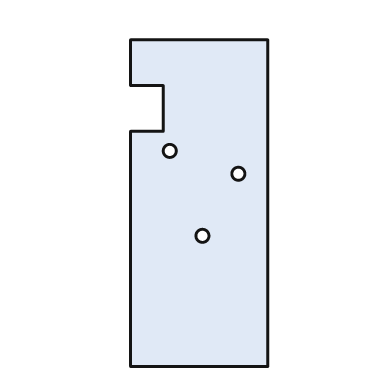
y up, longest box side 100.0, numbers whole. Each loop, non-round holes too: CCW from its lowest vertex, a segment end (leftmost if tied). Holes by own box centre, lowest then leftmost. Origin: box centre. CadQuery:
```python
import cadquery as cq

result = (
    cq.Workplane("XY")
    .moveTo(-21.0, -50.0)
    .lineTo(21.0, -50.0)
    .lineTo(21.0, 50.0)
    .lineTo(-21.0, 50.0)
    .lineTo(-21.0, 36.0)
    .lineTo(-11.0, 36.0)
    .lineTo(-11.0, 22.0)
    .lineTo(-21.0, 22.0)
    .close()
    .moveTo(1.0, -10.0)
    .circle(2.0)
    .moveTo(12.0, 9.0)
    .circle(2.0)
    .moveTo(-9.0, 16.0)
    .circle(2.0)
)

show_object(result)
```